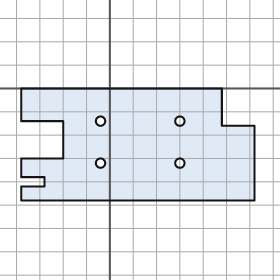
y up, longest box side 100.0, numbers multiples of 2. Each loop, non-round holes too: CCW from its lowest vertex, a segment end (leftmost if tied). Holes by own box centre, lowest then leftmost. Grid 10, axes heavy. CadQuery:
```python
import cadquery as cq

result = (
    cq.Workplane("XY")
    .moveTo(-38.0, -48.0)
    .lineTo(62.0, -48.0)
    .lineTo(62.0, -16.0)
    .lineTo(48.0, -16.0)
    .lineTo(48.0, 0.0)
    .lineTo(-38.0, 0.0)
    .lineTo(-38.0, -14.0)
    .lineTo(-20.0, -14.0)
    .lineTo(-20.0, -30.0)
    .lineTo(-38.0, -30.0)
    .lineTo(-38.0, -38.0)
    .lineTo(-28.0, -38.0)
    .lineTo(-28.0, -42.0)
    .lineTo(-38.0, -42.0)
    .close()
    .moveTo(-4.0, -32.0)
    .circle(2.0)
    .moveTo(30.0, -32.0)
    .circle(2.0)
    .moveTo(-4.0, -14.0)
    .circle(2.0)
    .moveTo(30.0, -14.0)
    .circle(2.0)
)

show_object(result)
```